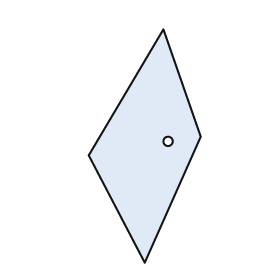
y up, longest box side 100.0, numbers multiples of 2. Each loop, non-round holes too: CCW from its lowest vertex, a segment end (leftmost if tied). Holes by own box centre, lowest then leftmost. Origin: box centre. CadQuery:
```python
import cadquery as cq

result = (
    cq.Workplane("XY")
    .moveTo(0.0, -50.0)
    .lineTo(24.0, 4.0)
    .lineTo(8.0, 50.0)
    .lineTo(-24.0, -4.0)
    .close()
    .moveTo(10.0, 2.0)
    .circle(2.0)
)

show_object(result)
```